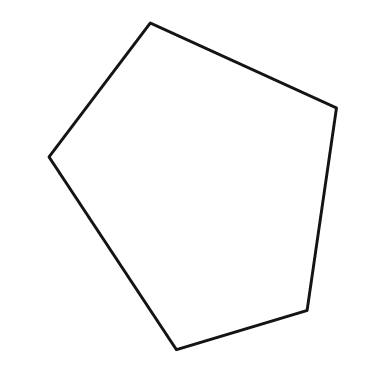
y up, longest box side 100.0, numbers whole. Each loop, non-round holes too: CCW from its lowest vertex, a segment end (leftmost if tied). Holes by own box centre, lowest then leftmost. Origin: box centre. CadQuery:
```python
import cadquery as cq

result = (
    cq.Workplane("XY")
    .moveTo(-5.0, -50.0)
    .lineTo(35.0, -38.0)
    .lineTo(44.0, 24.0)
    .lineTo(-13.0, 50.0)
    .lineTo(-44.0, 9.0)
    .close()
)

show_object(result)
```